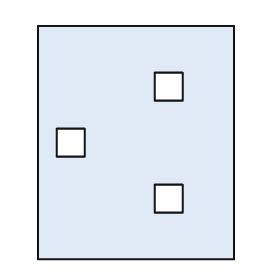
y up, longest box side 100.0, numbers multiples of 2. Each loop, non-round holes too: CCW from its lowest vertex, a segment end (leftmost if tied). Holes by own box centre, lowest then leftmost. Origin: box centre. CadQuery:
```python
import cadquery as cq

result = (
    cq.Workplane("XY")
    .moveTo(-42.0, -50.0)
    .lineTo(42.0, -50.0)
    .lineTo(42.0, 50.0)
    .lineTo(-42.0, 50.0)
    .close()
    .moveTo(8.0, -30.0)
    .lineTo(20.0, -30.0)
    .lineTo(20.0, -18.0)
    .lineTo(8.0, -18.0)
    .close()
    .moveTo(-34.0, -6.0)
    .lineTo(-22.0, -6.0)
    .lineTo(-22.0, 6.0)
    .lineTo(-34.0, 6.0)
    .close()
    .moveTo(8.0, 18.0)
    .lineTo(20.0, 18.0)
    .lineTo(20.0, 30.0)
    .lineTo(8.0, 30.0)
    .close()
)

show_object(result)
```